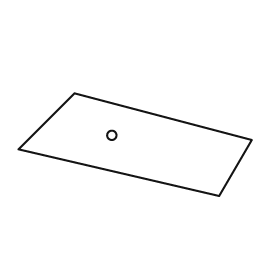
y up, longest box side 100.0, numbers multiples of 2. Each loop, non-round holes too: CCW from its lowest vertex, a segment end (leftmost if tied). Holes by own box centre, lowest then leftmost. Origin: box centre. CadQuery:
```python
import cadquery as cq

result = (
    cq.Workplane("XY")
    .moveTo(36.0, -22.0)
    .lineTo(50.0, 2.0)
    .lineTo(-26.0, 22.0)
    .lineTo(-50.0, -2.0)
    .close()
    .moveTo(-10.0, 4.0)
    .circle(2.0)
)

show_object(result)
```